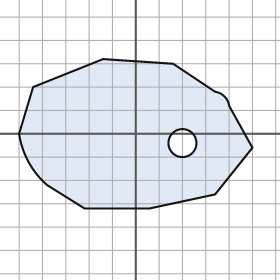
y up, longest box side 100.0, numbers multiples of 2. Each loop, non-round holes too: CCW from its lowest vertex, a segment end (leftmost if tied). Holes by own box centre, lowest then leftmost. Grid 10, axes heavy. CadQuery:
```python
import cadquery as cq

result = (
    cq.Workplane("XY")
    .moveTo(-22.0, -32.0)
    .lineTo(6.0, -32.0)
    .lineTo(34.0, -26.0)
    .lineTo(50.0, -6.0)
    .lineTo(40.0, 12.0)
    .threePointArc((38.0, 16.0), (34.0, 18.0))
    .lineTo(16.0, 30.0)
    .lineTo(-14.0, 32.0)
    .lineTo(-44.0, 20.0)
    .lineTo(-50.0, 0.0)
    .threePointArc((-46.0, -12.0), (-38.0, -22.0))
    .close()
    .moveTo(20.0, -4.0)
    .circle(6.0)
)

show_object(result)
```